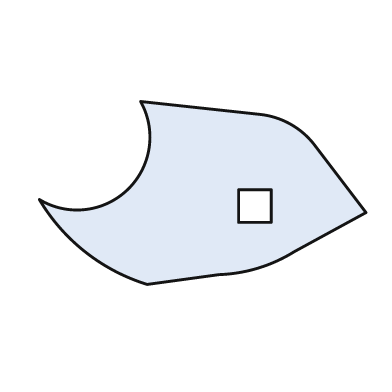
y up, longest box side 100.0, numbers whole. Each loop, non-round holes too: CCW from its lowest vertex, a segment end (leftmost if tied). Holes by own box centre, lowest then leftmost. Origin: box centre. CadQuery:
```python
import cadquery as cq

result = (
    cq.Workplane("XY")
    .moveTo(-17.0, -28.0)
    .lineTo(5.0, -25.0)
    .threePointArc((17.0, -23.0), (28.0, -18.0))
    .lineTo(50.0, -6.0)
    .lineTo(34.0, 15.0)
    .threePointArc((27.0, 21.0), (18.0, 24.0))
    .lineTo(-19.0, 28.0)
    .threePointArc((-23.0, 1.0), (-50.0, -2.0))
    .threePointArc((-36.0, -18.0), (-17.0, -28.0))
    .close()
    .moveTo(11.0, -9.0)
    .lineTo(21.0, -9.0)
    .lineTo(21.0, 1.0)
    .lineTo(11.0, 1.0)
    .close()
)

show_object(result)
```